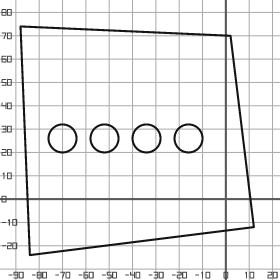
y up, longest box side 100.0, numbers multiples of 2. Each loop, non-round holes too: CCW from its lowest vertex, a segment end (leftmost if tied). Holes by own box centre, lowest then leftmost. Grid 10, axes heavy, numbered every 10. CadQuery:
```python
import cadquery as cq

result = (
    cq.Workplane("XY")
    .moveTo(-84.0, -24.0)
    .lineTo(12.0, -12.0)
    .lineTo(2.0, 70.0)
    .lineTo(-88.0, 74.0)
    .close()
    .moveTo(-70.0, 26.0)
    .circle(6.0)
    .moveTo(-52.0, 26.0)
    .circle(6.0)
    .moveTo(-34.0, 26.0)
    .circle(6.0)
    .moveTo(-16.0, 26.0)
    .circle(6.0)
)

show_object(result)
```